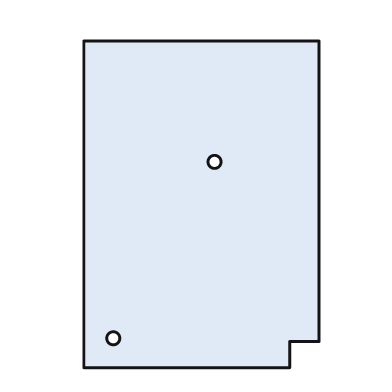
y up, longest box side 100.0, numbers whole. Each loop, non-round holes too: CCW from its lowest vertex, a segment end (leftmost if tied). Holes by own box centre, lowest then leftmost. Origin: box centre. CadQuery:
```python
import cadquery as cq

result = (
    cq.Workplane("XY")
    .moveTo(-36.0, -50.0)
    .lineTo(27.0, -50.0)
    .lineTo(27.0, -42.0)
    .lineTo(36.0, -42.0)
    .lineTo(36.0, 50.0)
    .lineTo(-36.0, 50.0)
    .close()
    .moveTo(-27.0, -41.0)
    .circle(2.0)
    .moveTo(4.0, 13.0)
    .circle(2.0)
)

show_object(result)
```